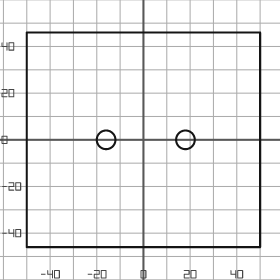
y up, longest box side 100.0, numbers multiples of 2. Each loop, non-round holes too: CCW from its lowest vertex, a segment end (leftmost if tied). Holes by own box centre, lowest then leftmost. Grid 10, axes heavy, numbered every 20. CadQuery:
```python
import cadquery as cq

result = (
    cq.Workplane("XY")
    .moveTo(-50.0, -46.0)
    .lineTo(50.0, -46.0)
    .lineTo(50.0, 46.0)
    .lineTo(-50.0, 46.0)
    .close()
    .moveTo(-16.0, 0.0)
    .circle(4.0)
    .moveTo(18.0, 0.0)
    .circle(4.0)
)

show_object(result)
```